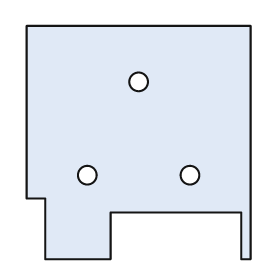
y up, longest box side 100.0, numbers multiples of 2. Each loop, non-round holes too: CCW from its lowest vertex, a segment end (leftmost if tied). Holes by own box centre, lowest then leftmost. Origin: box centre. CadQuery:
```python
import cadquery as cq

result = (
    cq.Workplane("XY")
    .moveTo(-40.0, -50.0)
    .lineTo(-12.0, -50.0)
    .lineTo(-12.0, -30.0)
    .lineTo(44.0, -30.0)
    .lineTo(44.0, -50.0)
    .lineTo(48.0, -50.0)
    .lineTo(48.0, 50.0)
    .lineTo(-48.0, 50.0)
    .lineTo(-48.0, -24.0)
    .lineTo(-40.0, -24.0)
    .close()
    .moveTo(-22.0, -14.0)
    .circle(4.0)
    .moveTo(22.0, -14.0)
    .circle(4.0)
    .moveTo(0.0, 26.0)
    .circle(4.0)
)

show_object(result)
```